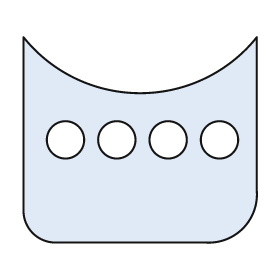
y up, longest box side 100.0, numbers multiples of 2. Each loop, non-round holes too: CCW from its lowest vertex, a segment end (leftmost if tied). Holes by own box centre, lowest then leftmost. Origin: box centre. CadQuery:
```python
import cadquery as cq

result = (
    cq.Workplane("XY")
    .moveTo(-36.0, -44.0)
    .lineTo(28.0, -44.0)
    .threePointArc((44.0, -38.0), (50.0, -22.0))
    .lineTo(50.0, 44.0)
    .threePointArc((0.0, 20.0), (-50.0, 44.0))
    .lineTo(-50.0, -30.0)
    .threePointArc((-46.0, -40.0), (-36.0, -44.0))
    .close()
    .moveTo(-32.0, 0.0)
    .circle(8.0)
    .moveTo(-10.0, 0.0)
    .circle(8.0)
    .moveTo(12.0, 0.0)
    .circle(8.0)
    .moveTo(34.0, 0.0)
    .circle(8.0)
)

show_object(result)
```